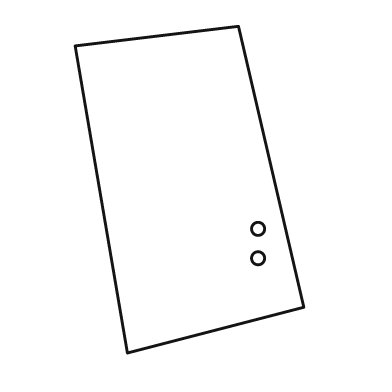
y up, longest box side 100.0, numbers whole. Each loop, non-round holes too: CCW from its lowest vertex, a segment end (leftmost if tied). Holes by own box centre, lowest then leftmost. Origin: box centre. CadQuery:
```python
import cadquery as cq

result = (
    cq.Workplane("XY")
    .moveTo(-19.0, -50.0)
    .lineTo(35.0, -36.0)
    .lineTo(15.0, 50.0)
    .lineTo(-35.0, 44.0)
    .close()
    .moveTo(21.0, -21.0)
    .circle(2.0)
    .moveTo(21.0, -12.0)
    .circle(2.0)
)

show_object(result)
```